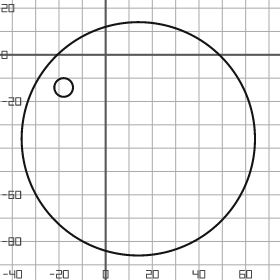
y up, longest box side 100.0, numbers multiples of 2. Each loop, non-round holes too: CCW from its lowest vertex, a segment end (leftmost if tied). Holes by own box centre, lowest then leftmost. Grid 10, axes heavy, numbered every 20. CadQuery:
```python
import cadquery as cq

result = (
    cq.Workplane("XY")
    .moveTo(14.0, -36.0)
    .circle(50.0)
    .moveTo(-18.0, -14.0)
    .circle(4.0)
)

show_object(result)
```